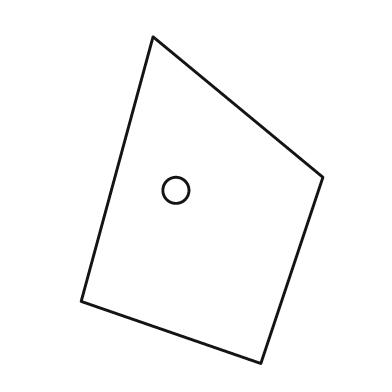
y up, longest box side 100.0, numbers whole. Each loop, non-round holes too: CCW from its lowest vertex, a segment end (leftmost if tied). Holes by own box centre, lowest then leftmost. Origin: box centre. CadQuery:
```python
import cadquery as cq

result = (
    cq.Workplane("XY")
    .moveTo(18.0, -50.0)
    .lineTo(37.0, 7.0)
    .lineTo(-15.0, 50.0)
    .lineTo(-37.0, -31.0)
    .close()
    .moveTo(-8.0, 3.0)
    .circle(4.0)
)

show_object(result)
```